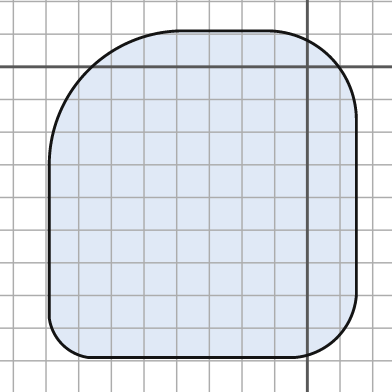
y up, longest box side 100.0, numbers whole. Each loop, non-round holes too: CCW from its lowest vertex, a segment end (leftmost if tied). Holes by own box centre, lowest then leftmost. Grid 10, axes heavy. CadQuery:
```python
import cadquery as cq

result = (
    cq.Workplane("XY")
    .moveTo(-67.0, -89.0)
    .lineTo(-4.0, -89.0)
    .threePointArc((9.0, -83.0), (15.0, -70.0))
    .lineTo(15.0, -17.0)
    .threePointArc((7.0, 3.0), (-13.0, 11.0))
    .lineTo(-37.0, 11.0)
    .threePointArc((-67.0, -1.0), (-79.0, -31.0))
    .lineTo(-79.0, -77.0)
    .threePointArc((-75.0, -85.0), (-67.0, -89.0))
    .close()
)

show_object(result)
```